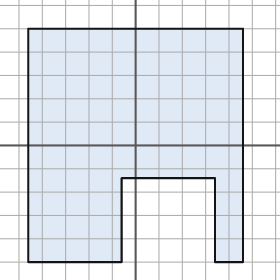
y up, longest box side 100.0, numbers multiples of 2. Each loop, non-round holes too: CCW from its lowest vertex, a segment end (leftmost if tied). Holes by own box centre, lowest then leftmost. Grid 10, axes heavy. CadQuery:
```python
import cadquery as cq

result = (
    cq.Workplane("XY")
    .moveTo(-46.0, -50.0)
    .lineTo(-6.0, -50.0)
    .lineTo(-6.0, -14.0)
    .lineTo(34.0, -14.0)
    .lineTo(34.0, -50.0)
    .lineTo(46.0, -50.0)
    .lineTo(46.0, 50.0)
    .lineTo(-46.0, 50.0)
    .close()
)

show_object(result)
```